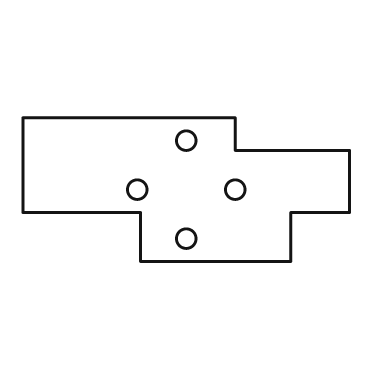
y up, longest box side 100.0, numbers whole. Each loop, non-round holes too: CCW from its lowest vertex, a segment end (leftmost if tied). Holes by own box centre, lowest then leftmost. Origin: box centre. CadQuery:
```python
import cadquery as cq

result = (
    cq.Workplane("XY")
    .moveTo(-14.0, -22.0)
    .lineTo(32.0, -22.0)
    .lineTo(32.0, -7.0)
    .lineTo(50.0, -7.0)
    .lineTo(50.0, 12.0)
    .lineTo(15.0, 12.0)
    .lineTo(15.0, 22.0)
    .lineTo(-50.0, 22.0)
    .lineTo(-50.0, -7.0)
    .lineTo(-14.0, -7.0)
    .close()
    .moveTo(0.0, -15.0)
    .circle(3.0)
    .moveTo(-15.0, 0.0)
    .circle(3.0)
    .moveTo(15.0, 0.0)
    .circle(3.0)
    .moveTo(0.0, 15.0)
    .circle(3.0)
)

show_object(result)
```